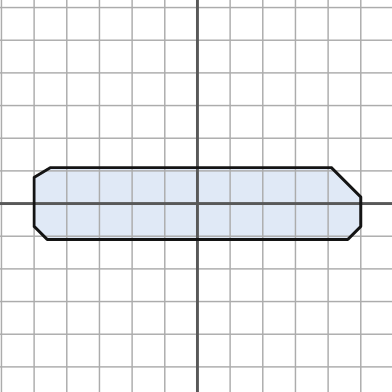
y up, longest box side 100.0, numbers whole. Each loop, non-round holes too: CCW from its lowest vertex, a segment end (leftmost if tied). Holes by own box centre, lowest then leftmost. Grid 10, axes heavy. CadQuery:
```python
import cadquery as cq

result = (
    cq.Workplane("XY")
    .moveTo(-46.0, -11.0)
    .lineTo(46.0, -11.0)
    .lineTo(50.0, -7.0)
    .lineTo(50.0, 2.0)
    .lineTo(41.0, 11.0)
    .lineTo(-45.0, 11.0)
    .lineTo(-50.0, 8.0)
    .lineTo(-50.0, -7.0)
    .close()
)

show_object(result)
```